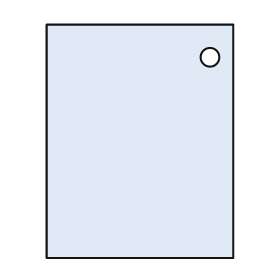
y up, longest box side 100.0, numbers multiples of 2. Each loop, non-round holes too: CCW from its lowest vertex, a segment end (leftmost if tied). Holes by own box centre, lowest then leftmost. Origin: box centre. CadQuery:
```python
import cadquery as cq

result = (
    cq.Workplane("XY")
    .moveTo(-40.0, -50.0)
    .lineTo(40.0, -50.0)
    .lineTo(40.0, 50.0)
    .lineTo(-40.0, 50.0)
    .close()
    .moveTo(30.0, 36.0)
    .circle(4.0)
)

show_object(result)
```